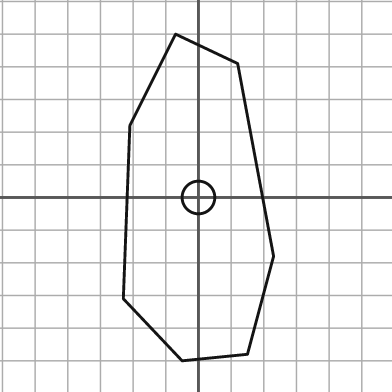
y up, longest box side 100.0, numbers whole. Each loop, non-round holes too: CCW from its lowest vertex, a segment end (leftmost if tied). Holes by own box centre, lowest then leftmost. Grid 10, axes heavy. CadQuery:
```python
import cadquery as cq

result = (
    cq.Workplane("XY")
    .moveTo(-5.0, -50.0)
    .lineTo(15.0, -48.0)
    .lineTo(23.0, -18.0)
    .lineTo(12.0, 41.0)
    .lineTo(-7.0, 50.0)
    .lineTo(-21.0, 22.0)
    .lineTo(-23.0, -31.0)
    .close()
    .moveTo(0.0, 0.0)
    .circle(5.0)
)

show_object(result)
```